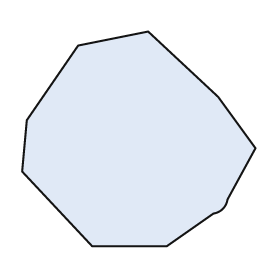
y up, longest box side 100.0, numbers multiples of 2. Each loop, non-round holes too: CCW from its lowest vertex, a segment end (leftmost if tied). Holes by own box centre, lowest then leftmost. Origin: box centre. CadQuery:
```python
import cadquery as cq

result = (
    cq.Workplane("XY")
    .moveTo(-20.0, -46.0)
    .lineTo(12.0, -46.0)
    .lineTo(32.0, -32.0)
    .threePointArc((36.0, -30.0), (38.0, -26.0))
    .lineTo(50.0, -4.0)
    .lineTo(34.0, 18.0)
    .lineTo(4.0, 46.0)
    .lineTo(-26.0, 40.0)
    .lineTo(-48.0, 8.0)
    .lineTo(-50.0, -14.0)
    .close()
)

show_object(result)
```